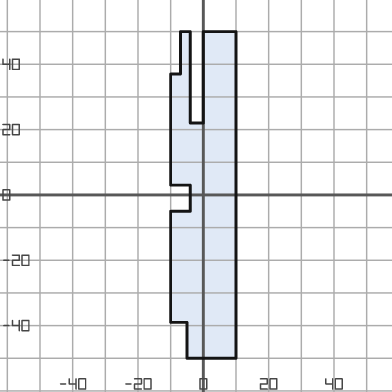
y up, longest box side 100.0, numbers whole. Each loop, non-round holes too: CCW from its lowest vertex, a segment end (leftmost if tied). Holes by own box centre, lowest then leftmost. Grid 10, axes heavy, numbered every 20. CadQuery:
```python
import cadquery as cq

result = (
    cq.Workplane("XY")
    .moveTo(-5.0, -50.0)
    .lineTo(10.0, -50.0)
    .lineTo(10.0, 50.0)
    .lineTo(0.0, 50.0)
    .lineTo(0.0, 22.0)
    .lineTo(-4.0, 22.0)
    .lineTo(-4.0, 50.0)
    .lineTo(-7.0, 50.0)
    .lineTo(-7.0, 37.0)
    .lineTo(-10.0, 37.0)
    .lineTo(-10.0, 3.0)
    .lineTo(-4.0, 3.0)
    .lineTo(-4.0, -5.0)
    .lineTo(-10.0, -5.0)
    .lineTo(-10.0, -39.0)
    .lineTo(-5.0, -39.0)
    .close()
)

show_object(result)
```